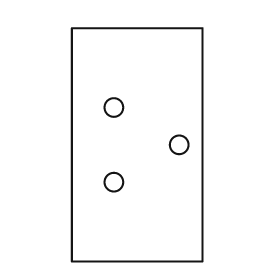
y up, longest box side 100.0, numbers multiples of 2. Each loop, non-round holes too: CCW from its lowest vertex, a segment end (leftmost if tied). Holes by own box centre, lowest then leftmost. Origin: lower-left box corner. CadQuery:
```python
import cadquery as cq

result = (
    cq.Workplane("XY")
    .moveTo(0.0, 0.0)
    .lineTo(56.0, 0.0)
    .lineTo(56.0, 100.0)
    .lineTo(0.0, 100.0)
    .close()
    .moveTo(18.0, 34.0)
    .circle(4.0)
    .moveTo(46.0, 50.0)
    .circle(4.0)
    .moveTo(18.0, 66.0)
    .circle(4.0)
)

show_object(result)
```